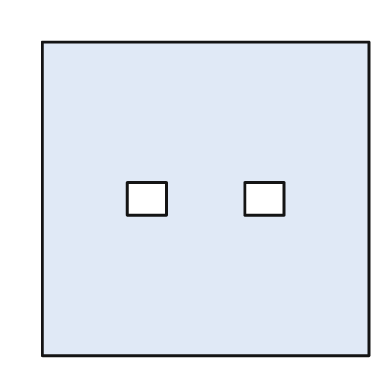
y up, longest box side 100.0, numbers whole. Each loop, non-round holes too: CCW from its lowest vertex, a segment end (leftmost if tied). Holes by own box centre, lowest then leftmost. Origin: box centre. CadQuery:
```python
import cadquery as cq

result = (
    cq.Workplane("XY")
    .moveTo(-50.0, -48.0)
    .lineTo(50.0, -48.0)
    .lineTo(50.0, 48.0)
    .lineTo(-50.0, 48.0)
    .close()
    .moveTo(-24.0, -5.0)
    .lineTo(-12.0, -5.0)
    .lineTo(-12.0, 5.0)
    .lineTo(-24.0, 5.0)
    .close()
    .moveTo(12.0, -5.0)
    .lineTo(24.0, -5.0)
    .lineTo(24.0, 5.0)
    .lineTo(12.0, 5.0)
    .close()
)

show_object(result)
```